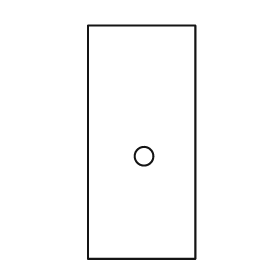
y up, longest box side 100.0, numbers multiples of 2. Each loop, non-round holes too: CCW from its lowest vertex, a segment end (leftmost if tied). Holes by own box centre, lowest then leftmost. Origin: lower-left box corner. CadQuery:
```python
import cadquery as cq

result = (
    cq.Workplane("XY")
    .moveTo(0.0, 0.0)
    .lineTo(46.0, 0.0)
    .lineTo(46.0, 100.0)
    .lineTo(0.0, 100.0)
    .close()
    .moveTo(24.0, 44.0)
    .circle(4.0)
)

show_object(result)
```